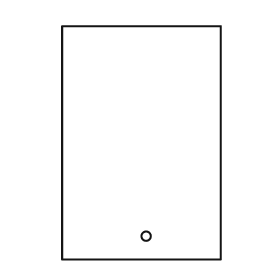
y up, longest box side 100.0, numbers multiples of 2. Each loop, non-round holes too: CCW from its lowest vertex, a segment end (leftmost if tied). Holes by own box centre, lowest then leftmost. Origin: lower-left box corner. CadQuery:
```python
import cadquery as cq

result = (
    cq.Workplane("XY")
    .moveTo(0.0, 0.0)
    .lineTo(68.0, 0.0)
    .lineTo(68.0, 100.0)
    .lineTo(0.0, 100.0)
    .close()
    .moveTo(36.0, 10.0)
    .circle(2.0)
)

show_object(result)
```